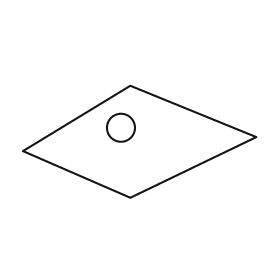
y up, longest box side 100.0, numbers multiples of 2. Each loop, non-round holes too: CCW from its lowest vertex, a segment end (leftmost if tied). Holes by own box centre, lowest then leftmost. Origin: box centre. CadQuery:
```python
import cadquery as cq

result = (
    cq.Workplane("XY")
    .moveTo(-4.0, -24.0)
    .lineTo(50.0, 2.0)
    .lineTo(-4.0, 24.0)
    .lineTo(-50.0, -4.0)
    .close()
    .moveTo(-8.0, 6.0)
    .circle(6.0)
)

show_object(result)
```